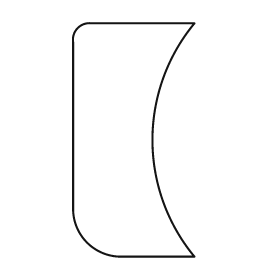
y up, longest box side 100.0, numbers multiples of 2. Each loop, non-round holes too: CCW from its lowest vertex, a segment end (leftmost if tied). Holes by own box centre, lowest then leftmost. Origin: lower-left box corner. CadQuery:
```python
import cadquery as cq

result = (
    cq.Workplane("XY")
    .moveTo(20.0, 0.0)
    .lineTo(52.0, 0.0)
    .threePointArc((34.0, 50.0), (52.0, 100.0))
    .lineTo(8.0, 100.0)
    .threePointArc((2.0, 98.0), (0.0, 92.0))
    .lineTo(0.0, 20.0)
    .threePointArc((6.0, 6.0), (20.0, 0.0))
    .close()
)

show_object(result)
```